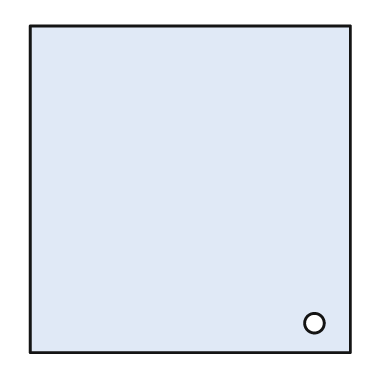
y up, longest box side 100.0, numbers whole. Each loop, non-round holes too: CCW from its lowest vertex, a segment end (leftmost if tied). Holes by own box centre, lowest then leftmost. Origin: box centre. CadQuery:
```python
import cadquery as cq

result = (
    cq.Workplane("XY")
    .moveTo(-49.0, -50.0)
    .lineTo(49.0, -50.0)
    .lineTo(49.0, 50.0)
    .lineTo(-49.0, 50.0)
    .close()
    .moveTo(38.0, -41.0)
    .circle(3.0)
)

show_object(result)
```